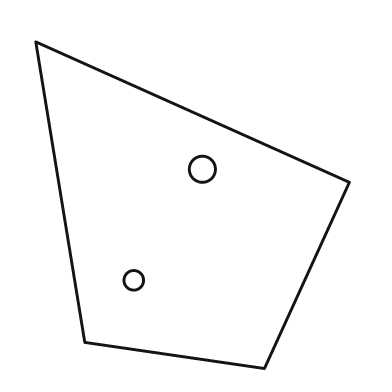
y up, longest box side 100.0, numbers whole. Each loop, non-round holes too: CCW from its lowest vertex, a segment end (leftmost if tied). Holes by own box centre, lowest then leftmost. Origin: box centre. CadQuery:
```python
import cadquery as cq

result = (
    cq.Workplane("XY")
    .moveTo(22.0, -50.0)
    .lineTo(48.0, 7.0)
    .lineTo(-48.0, 50.0)
    .lineTo(-33.0, -42.0)
    .close()
    .moveTo(-18.0, -23.0)
    .circle(3.0)
    .moveTo(3.0, 11.0)
    .circle(4.0)
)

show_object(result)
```